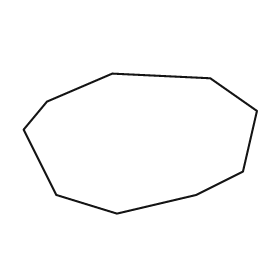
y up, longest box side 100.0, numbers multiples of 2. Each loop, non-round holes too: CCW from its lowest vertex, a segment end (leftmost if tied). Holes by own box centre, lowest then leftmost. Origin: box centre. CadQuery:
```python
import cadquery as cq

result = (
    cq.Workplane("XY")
    .moveTo(-10.0, -30.0)
    .lineTo(24.0, -22.0)
    .lineTo(44.0, -12.0)
    .lineTo(50.0, 14.0)
    .lineTo(30.0, 28.0)
    .lineTo(-12.0, 30.0)
    .lineTo(-40.0, 18.0)
    .lineTo(-50.0, 6.0)
    .lineTo(-36.0, -22.0)
    .close()
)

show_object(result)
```